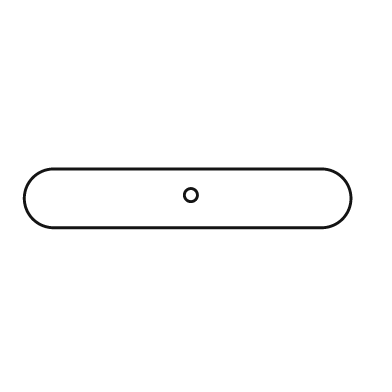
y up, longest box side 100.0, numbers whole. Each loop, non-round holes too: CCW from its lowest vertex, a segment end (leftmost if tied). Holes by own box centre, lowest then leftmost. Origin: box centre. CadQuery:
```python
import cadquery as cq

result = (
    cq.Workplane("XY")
    .moveTo(-41.0, -9.0)
    .lineTo(41.0, -9.0)
    .threePointArc((50.0, 0.0), (41.0, 9.0))
    .lineTo(-41.0, 9.0)
    .threePointArc((-50.0, 0.0), (-41.0, -9.0))
    .close()
    .moveTo(1.0, 1.0)
    .circle(2.0)
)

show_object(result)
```